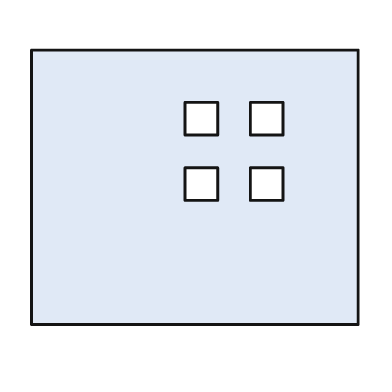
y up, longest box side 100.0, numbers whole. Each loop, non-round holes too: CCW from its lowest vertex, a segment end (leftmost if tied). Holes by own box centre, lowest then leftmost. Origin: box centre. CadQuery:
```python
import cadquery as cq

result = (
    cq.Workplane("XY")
    .moveTo(-50.0, -42.0)
    .lineTo(50.0, -42.0)
    .lineTo(50.0, 42.0)
    .lineTo(-50.0, 42.0)
    .close()
    .moveTo(-3.0, -4.0)
    .lineTo(7.0, -4.0)
    .lineTo(7.0, 6.0)
    .lineTo(-3.0, 6.0)
    .close()
    .moveTo(17.0, -4.0)
    .lineTo(27.0, -4.0)
    .lineTo(27.0, 6.0)
    .lineTo(17.0, 6.0)
    .close()
    .moveTo(-3.0, 16.0)
    .lineTo(7.0, 16.0)
    .lineTo(7.0, 26.0)
    .lineTo(-3.0, 26.0)
    .close()
    .moveTo(17.0, 16.0)
    .lineTo(27.0, 16.0)
    .lineTo(27.0, 26.0)
    .lineTo(17.0, 26.0)
    .close()
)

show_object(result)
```